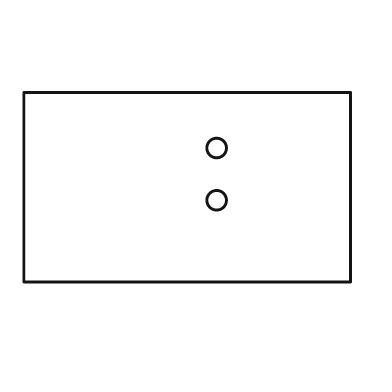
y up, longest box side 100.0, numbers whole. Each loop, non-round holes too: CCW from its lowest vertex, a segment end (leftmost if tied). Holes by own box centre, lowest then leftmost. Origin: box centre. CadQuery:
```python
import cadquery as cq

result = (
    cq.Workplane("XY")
    .moveTo(-50.0, -29.0)
    .lineTo(50.0, -29.0)
    .lineTo(50.0, 29.0)
    .lineTo(-50.0, 29.0)
    .close()
    .moveTo(9.0, -4.0)
    .circle(3.0)
    .moveTo(9.0, 12.0)
    .circle(3.0)
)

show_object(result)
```